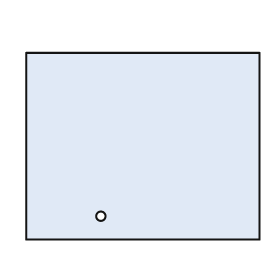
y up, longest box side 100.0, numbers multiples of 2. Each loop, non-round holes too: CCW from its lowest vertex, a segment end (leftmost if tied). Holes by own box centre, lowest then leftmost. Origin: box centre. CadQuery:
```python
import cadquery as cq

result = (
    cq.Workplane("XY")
    .moveTo(-50.0, -40.0)
    .lineTo(50.0, -40.0)
    .lineTo(50.0, 40.0)
    .lineTo(-50.0, 40.0)
    .close()
    .moveTo(-18.0, -30.0)
    .circle(2.0)
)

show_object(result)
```